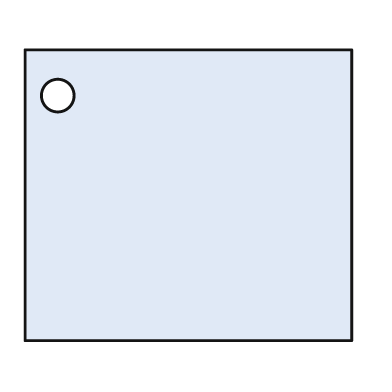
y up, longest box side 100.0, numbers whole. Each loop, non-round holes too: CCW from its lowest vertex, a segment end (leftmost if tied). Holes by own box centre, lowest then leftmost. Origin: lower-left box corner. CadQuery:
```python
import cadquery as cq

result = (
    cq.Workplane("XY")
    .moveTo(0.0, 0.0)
    .lineTo(100.0, 0.0)
    .lineTo(100.0, 89.0)
    .lineTo(0.0, 89.0)
    .close()
    .moveTo(10.0, 75.0)
    .circle(5.0)
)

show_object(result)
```